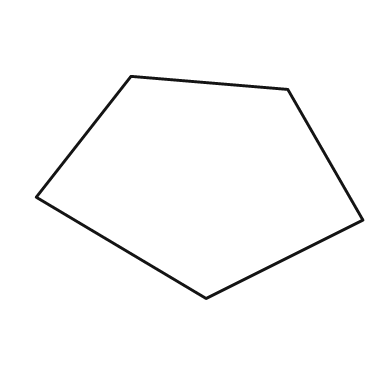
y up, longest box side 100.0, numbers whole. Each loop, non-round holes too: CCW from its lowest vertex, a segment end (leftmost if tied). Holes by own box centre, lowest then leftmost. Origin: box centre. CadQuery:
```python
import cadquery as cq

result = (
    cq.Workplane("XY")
    .moveTo(2.0, -34.0)
    .lineTo(50.0, -10.0)
    .lineTo(27.0, 30.0)
    .lineTo(-21.0, 34.0)
    .lineTo(-50.0, -3.0)
    .close()
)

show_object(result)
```